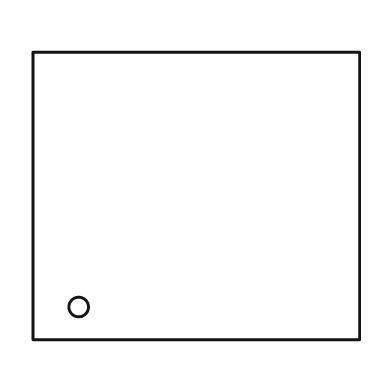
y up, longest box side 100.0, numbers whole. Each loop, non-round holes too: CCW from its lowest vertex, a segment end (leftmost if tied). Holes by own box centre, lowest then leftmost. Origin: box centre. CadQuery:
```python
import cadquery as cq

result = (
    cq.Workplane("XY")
    .moveTo(-50.0, -44.0)
    .lineTo(50.0, -44.0)
    .lineTo(50.0, 44.0)
    .lineTo(-50.0, 44.0)
    .close()
    .moveTo(-36.0, -34.0)
    .circle(3.0)
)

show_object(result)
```